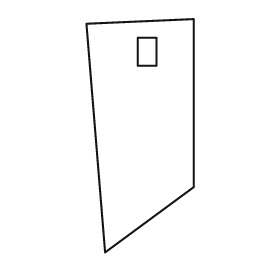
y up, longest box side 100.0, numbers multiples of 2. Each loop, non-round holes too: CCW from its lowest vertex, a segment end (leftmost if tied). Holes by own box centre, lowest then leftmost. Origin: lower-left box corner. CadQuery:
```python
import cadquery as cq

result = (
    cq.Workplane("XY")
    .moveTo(8.0, 0.0)
    .lineTo(46.0, 28.0)
    .lineTo(46.0, 100.0)
    .lineTo(0.0, 98.0)
    .close()
    .moveTo(22.0, 80.0)
    .lineTo(30.0, 80.0)
    .lineTo(30.0, 92.0)
    .lineTo(22.0, 92.0)
    .close()
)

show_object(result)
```